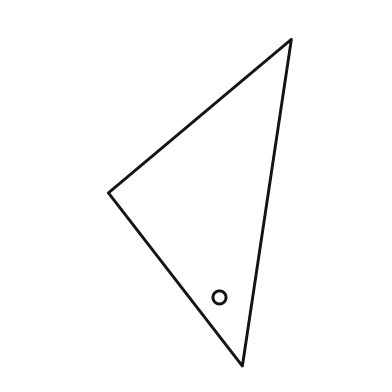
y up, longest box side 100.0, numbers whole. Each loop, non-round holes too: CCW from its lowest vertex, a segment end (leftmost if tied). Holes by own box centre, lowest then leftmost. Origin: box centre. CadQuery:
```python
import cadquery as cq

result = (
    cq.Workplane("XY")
    .moveTo(13.0, -50.0)
    .lineTo(28.0, 50.0)
    .lineTo(-28.0, 3.0)
    .close()
    .moveTo(6.0, -29.0)
    .circle(2.0)
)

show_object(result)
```